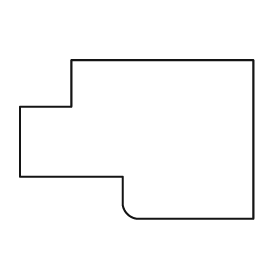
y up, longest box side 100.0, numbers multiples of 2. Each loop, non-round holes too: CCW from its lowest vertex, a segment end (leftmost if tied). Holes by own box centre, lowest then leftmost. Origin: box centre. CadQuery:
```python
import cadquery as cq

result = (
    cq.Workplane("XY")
    .moveTo(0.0, -34.0)
    .lineTo(50.0, -34.0)
    .lineTo(50.0, 34.0)
    .lineTo(-28.0, 34.0)
    .lineTo(-28.0, 14.0)
    .lineTo(-50.0, 14.0)
    .lineTo(-50.0, -16.0)
    .lineTo(-6.0, -16.0)
    .lineTo(-6.0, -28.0)
    .threePointArc((-4.0, -32.0), (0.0, -34.0))
    .close()
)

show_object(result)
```